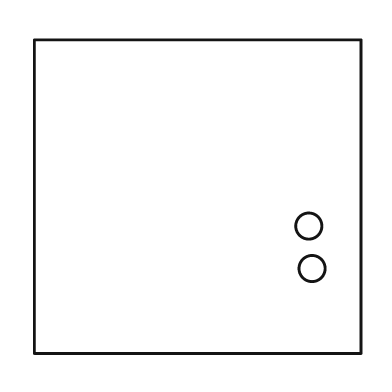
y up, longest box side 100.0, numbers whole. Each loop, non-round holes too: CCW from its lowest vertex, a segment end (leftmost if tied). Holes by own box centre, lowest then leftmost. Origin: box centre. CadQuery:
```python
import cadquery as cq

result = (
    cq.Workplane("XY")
    .moveTo(-50.0, -48.0)
    .lineTo(50.0, -48.0)
    .lineTo(50.0, 48.0)
    .lineTo(-50.0, 48.0)
    .close()
    .moveTo(35.0, -22.0)
    .circle(4.0)
    .moveTo(34.0, -9.0)
    .circle(4.0)
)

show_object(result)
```